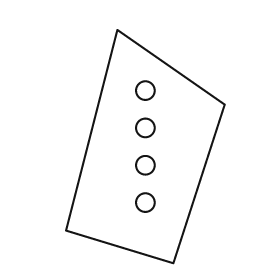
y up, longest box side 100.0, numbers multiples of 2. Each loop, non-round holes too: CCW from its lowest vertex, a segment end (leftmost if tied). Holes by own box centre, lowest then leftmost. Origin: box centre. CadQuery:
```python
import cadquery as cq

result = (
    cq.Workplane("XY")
    .moveTo(12.0, -50.0)
    .lineTo(34.0, 18.0)
    .lineTo(-12.0, 50.0)
    .lineTo(-34.0, -36.0)
    .close()
    .moveTo(0.0, -24.0)
    .circle(4.0)
    .moveTo(0.0, -8.0)
    .circle(4.0)
    .moveTo(0.0, 8.0)
    .circle(4.0)
    .moveTo(0.0, 24.0)
    .circle(4.0)
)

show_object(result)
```